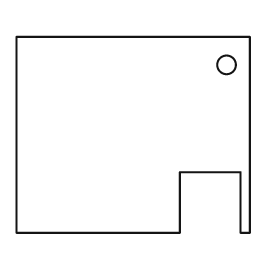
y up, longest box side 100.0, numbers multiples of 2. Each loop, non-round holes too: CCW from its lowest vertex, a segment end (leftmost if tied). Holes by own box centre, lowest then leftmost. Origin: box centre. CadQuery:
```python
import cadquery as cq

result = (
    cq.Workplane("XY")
    .moveTo(-50.0, -42.0)
    .lineTo(20.0, -42.0)
    .lineTo(20.0, -16.0)
    .lineTo(46.0, -16.0)
    .lineTo(46.0, -42.0)
    .lineTo(50.0, -42.0)
    .lineTo(50.0, 42.0)
    .lineTo(-50.0, 42.0)
    .close()
    .moveTo(40.0, 30.0)
    .circle(4.0)
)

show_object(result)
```